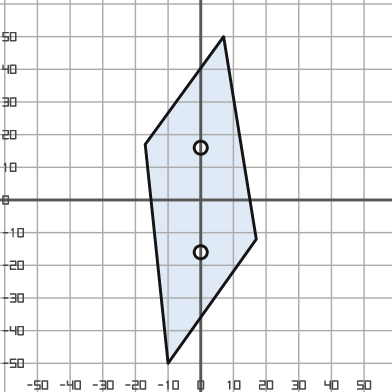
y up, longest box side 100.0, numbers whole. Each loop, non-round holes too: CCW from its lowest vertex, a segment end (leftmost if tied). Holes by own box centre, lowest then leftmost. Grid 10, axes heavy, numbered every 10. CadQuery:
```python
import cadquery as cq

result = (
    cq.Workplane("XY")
    .moveTo(-10.0, -50.0)
    .lineTo(17.0, -12.0)
    .lineTo(7.0, 50.0)
    .lineTo(-17.0, 17.0)
    .close()
    .moveTo(0.0, -16.0)
    .circle(2.0)
    .moveTo(0.0, 16.0)
    .circle(2.0)
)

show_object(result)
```